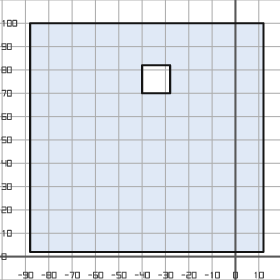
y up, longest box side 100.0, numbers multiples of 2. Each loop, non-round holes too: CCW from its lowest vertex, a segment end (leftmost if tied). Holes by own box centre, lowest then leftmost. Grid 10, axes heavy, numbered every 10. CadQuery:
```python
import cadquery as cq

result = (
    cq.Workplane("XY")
    .moveTo(-88.0, 2.0)
    .lineTo(12.0, 2.0)
    .lineTo(12.0, 100.0)
    .lineTo(-88.0, 100.0)
    .close()
    .moveTo(-40.0, 70.0)
    .lineTo(-28.0, 70.0)
    .lineTo(-28.0, 82.0)
    .lineTo(-40.0, 82.0)
    .close()
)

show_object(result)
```